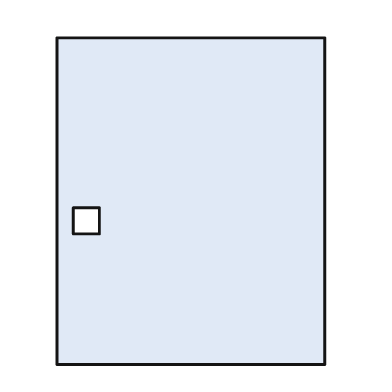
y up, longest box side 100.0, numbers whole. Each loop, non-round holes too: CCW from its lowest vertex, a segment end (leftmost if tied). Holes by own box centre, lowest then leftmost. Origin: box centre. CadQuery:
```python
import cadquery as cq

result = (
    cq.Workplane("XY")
    .moveTo(-41.0, -50.0)
    .lineTo(41.0, -50.0)
    .lineTo(41.0, 50.0)
    .lineTo(-41.0, 50.0)
    .close()
    .moveTo(-36.0, -10.0)
    .lineTo(-28.0, -10.0)
    .lineTo(-28.0, -2.0)
    .lineTo(-36.0, -2.0)
    .close()
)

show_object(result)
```